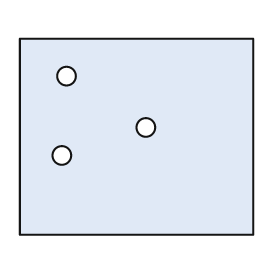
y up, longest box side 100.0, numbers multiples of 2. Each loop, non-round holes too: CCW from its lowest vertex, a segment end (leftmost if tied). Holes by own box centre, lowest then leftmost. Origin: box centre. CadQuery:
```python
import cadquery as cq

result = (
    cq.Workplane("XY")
    .moveTo(-50.0, -42.0)
    .lineTo(50.0, -42.0)
    .lineTo(50.0, 42.0)
    .lineTo(-50.0, 42.0)
    .close()
    .moveTo(-32.0, -8.0)
    .circle(4.0)
    .moveTo(4.0, 4.0)
    .circle(4.0)
    .moveTo(-30.0, 26.0)
    .circle(4.0)
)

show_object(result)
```